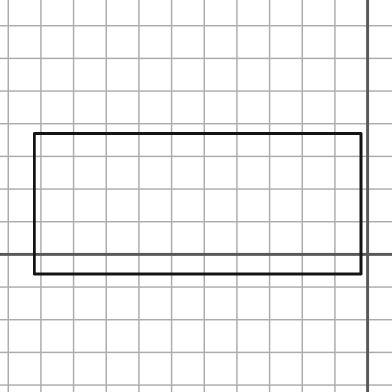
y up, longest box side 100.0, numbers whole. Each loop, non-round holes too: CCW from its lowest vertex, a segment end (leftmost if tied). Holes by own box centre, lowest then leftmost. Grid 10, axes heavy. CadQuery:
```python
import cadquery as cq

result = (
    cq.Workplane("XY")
    .moveTo(-102.0, -6.0)
    .lineTo(-2.0, -6.0)
    .lineTo(-2.0, 37.0)
    .lineTo(-102.0, 37.0)
    .close()
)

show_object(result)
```